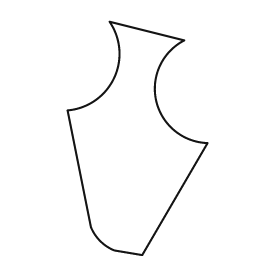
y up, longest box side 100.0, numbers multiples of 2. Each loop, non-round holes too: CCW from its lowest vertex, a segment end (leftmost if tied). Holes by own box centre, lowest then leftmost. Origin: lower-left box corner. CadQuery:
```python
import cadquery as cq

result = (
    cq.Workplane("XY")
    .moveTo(32.0, 0.0)
    .lineTo(60.0, 48.0)
    .threePointArc((38.0, 66.0), (50.0, 92.0))
    .lineTo(18.0, 100.0)
    .threePointArc((20.0, 76.0), (0.0, 62.0))
    .lineTo(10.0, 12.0)
    .threePointArc((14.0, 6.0), (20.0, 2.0))
    .close()
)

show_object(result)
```